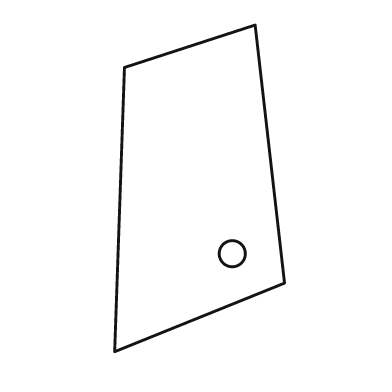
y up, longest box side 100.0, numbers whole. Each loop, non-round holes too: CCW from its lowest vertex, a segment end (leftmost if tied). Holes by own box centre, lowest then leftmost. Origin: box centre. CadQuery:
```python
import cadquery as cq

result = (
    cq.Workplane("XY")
    .moveTo(-26.0, -50.0)
    .lineTo(26.0, -29.0)
    .lineTo(17.0, 50.0)
    .lineTo(-23.0, 37.0)
    .close()
    .moveTo(10.0, -20.0)
    .circle(4.0)
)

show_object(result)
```